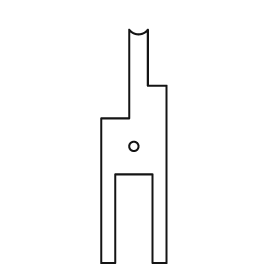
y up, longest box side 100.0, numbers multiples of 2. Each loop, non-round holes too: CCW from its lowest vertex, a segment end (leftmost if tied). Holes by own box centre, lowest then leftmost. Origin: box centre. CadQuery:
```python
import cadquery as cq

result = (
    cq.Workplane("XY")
    .moveTo(-14.0, -50.0)
    .lineTo(-8.0, -50.0)
    .lineTo(-8.0, -12.0)
    .lineTo(8.0, -12.0)
    .lineTo(8.0, -50.0)
    .lineTo(14.0, -50.0)
    .lineTo(14.0, 26.0)
    .lineTo(6.0, 26.0)
    .lineTo(6.0, 50.0)
    .threePointArc((2.0, 48.0), (-2.0, 50.0))
    .lineTo(-2.0, 12.0)
    .lineTo(-14.0, 12.0)
    .close()
    .moveTo(0.0, 0.0)
    .circle(2.0)
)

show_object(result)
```